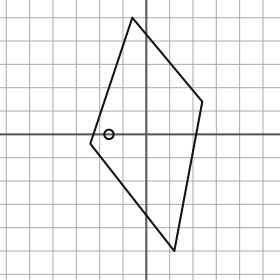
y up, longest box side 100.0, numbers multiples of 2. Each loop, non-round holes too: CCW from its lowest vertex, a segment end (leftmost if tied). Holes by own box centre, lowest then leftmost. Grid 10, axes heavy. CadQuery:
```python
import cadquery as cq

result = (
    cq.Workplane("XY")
    .moveTo(12.0, -50.0)
    .lineTo(24.0, 14.0)
    .lineTo(-6.0, 50.0)
    .lineTo(-24.0, -4.0)
    .close()
    .moveTo(-16.0, 0.0)
    .circle(2.0)
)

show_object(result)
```